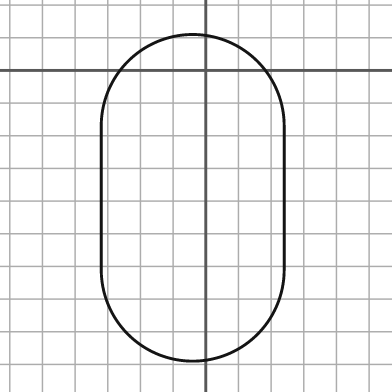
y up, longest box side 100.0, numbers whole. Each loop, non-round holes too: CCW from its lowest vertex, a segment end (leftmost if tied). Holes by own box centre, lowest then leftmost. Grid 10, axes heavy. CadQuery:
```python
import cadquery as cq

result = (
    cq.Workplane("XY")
    .moveTo(-32.0, -61.0)
    .threePointArc((-4.0, -89.0), (24.0, -61.0))
    .lineTo(24.0, -17.0)
    .threePointArc((-4.0, 11.0), (-32.0, -17.0))
    .close()
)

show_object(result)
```